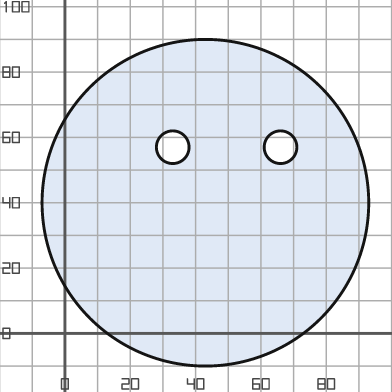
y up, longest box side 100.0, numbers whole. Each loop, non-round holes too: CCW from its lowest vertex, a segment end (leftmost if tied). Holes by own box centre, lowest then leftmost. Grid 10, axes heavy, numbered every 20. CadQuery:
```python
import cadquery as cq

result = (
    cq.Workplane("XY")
    .moveTo(43.0, 40.0)
    .circle(50.0)
    .moveTo(33.0, 57.0)
    .circle(5.0)
    .moveTo(66.0, 57.0)
    .circle(5.0)
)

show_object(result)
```